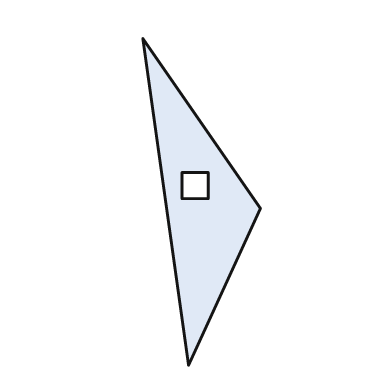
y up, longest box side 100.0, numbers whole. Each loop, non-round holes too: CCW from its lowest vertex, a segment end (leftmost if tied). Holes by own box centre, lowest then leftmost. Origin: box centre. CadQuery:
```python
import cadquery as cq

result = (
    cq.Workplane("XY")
    .moveTo(-4.0, -50.0)
    .lineTo(18.0, -2.0)
    .lineTo(-18.0, 50.0)
    .close()
    .moveTo(-6.0, 1.0)
    .lineTo(2.0, 1.0)
    .lineTo(2.0, 9.0)
    .lineTo(-6.0, 9.0)
    .close()
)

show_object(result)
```